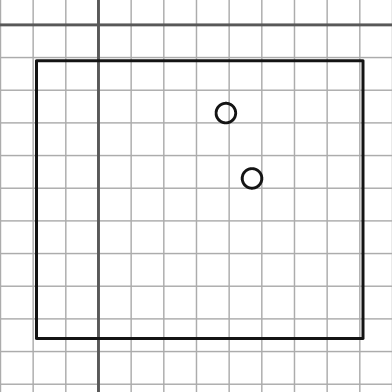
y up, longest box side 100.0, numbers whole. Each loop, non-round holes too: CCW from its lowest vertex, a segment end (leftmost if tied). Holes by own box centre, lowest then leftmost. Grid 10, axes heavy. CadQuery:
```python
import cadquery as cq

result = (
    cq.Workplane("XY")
    .moveTo(-19.0, -96.0)
    .lineTo(81.0, -96.0)
    .lineTo(81.0, -11.0)
    .lineTo(-19.0, -11.0)
    .close()
    .moveTo(47.0, -47.0)
    .circle(3.0)
    .moveTo(39.0, -27.0)
    .circle(3.0)
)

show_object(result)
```